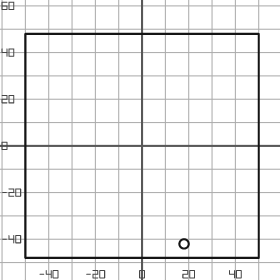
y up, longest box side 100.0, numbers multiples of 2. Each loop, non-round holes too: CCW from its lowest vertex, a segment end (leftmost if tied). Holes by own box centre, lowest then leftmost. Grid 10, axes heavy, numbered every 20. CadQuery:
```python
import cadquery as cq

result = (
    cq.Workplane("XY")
    .moveTo(-50.0, -48.0)
    .lineTo(50.0, -48.0)
    .lineTo(50.0, 48.0)
    .lineTo(-50.0, 48.0)
    .close()
    .moveTo(18.0, -42.0)
    .circle(2.0)
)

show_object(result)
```